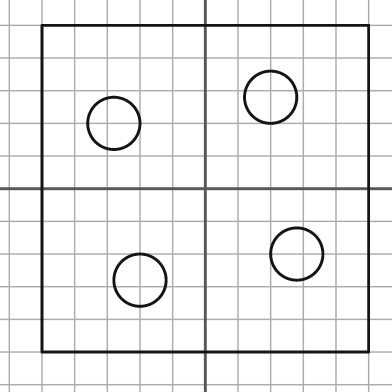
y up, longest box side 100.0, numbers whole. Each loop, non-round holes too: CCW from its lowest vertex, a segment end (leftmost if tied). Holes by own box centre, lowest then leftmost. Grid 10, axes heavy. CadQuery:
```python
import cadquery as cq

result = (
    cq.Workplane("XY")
    .moveTo(-50.0, -50.0)
    .lineTo(50.0, -50.0)
    .lineTo(50.0, 50.0)
    .lineTo(-50.0, 50.0)
    .close()
    .moveTo(-20.0, -28.0)
    .circle(8.0)
    .moveTo(28.0, -20.0)
    .circle(8.0)
    .moveTo(-28.0, 20.0)
    .circle(8.0)
    .moveTo(20.0, 28.0)
    .circle(8.0)
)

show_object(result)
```